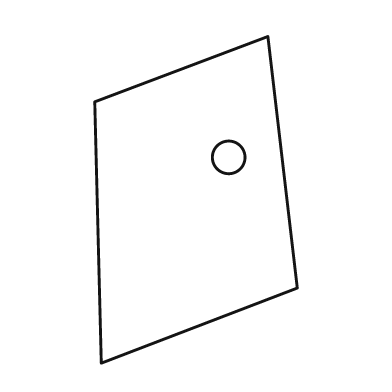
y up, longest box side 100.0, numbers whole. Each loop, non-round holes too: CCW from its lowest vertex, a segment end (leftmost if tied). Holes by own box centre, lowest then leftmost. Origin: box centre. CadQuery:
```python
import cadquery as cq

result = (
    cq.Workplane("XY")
    .moveTo(-29.0, -50.0)
    .lineTo(31.0, -27.0)
    .lineTo(22.0, 50.0)
    .lineTo(-31.0, 30.0)
    .close()
    .moveTo(10.0, 13.0)
    .circle(5.0)
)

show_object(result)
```